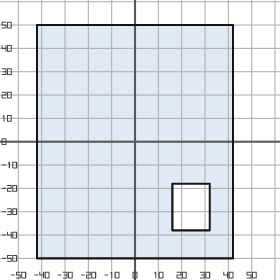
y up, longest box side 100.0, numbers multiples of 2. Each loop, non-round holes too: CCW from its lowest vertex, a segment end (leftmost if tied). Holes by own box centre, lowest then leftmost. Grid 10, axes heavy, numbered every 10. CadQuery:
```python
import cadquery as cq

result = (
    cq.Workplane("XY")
    .moveTo(-42.0, -50.0)
    .lineTo(42.0, -50.0)
    .lineTo(42.0, 50.0)
    .lineTo(-42.0, 50.0)
    .close()
    .moveTo(16.0, -38.0)
    .lineTo(32.0, -38.0)
    .lineTo(32.0, -18.0)
    .lineTo(16.0, -18.0)
    .close()
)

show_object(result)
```